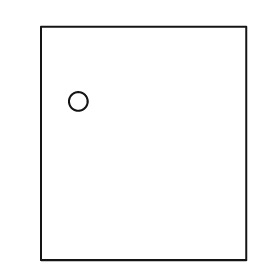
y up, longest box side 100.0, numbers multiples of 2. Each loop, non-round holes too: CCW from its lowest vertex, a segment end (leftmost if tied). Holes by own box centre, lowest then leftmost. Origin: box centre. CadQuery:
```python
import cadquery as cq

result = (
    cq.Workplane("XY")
    .moveTo(-44.0, -50.0)
    .lineTo(44.0, -50.0)
    .lineTo(44.0, 50.0)
    .lineTo(-44.0, 50.0)
    .close()
    .moveTo(-28.0, 18.0)
    .circle(4.0)
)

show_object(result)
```